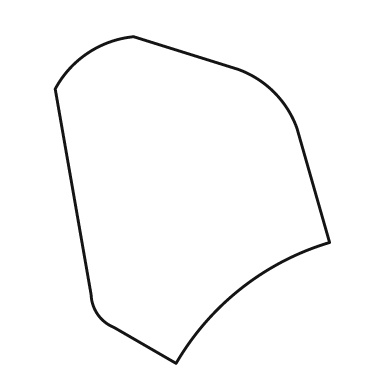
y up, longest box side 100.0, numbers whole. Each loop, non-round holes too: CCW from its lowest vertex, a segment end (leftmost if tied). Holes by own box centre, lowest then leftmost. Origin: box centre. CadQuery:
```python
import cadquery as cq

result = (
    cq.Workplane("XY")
    .moveTo(-5.0, -50.0)
    .threePointArc((15.0, -27.0), (42.0, -13.0))
    .lineTo(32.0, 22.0)
    .threePointArc((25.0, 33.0), (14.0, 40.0))
    .lineTo(-18.0, 50.0)
    .threePointArc((-32.0, 45.0), (-42.0, 34.0))
    .lineTo(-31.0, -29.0)
    .threePointArc((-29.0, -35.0), (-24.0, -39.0))
    .close()
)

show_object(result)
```